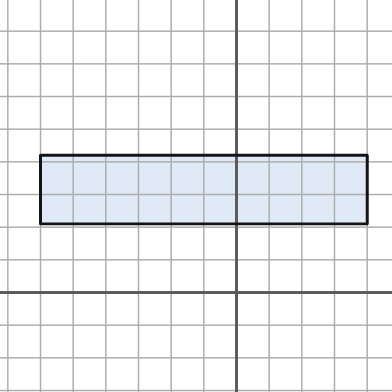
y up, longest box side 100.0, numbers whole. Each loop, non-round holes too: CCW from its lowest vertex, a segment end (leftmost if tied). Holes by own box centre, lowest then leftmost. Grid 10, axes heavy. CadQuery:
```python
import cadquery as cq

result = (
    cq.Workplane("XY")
    .moveTo(-60.0, 21.0)
    .lineTo(40.0, 21.0)
    .lineTo(40.0, 42.0)
    .lineTo(-60.0, 42.0)
    .close()
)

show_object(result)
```